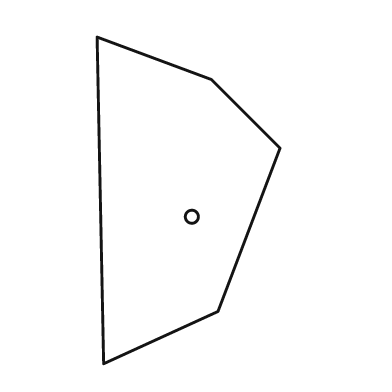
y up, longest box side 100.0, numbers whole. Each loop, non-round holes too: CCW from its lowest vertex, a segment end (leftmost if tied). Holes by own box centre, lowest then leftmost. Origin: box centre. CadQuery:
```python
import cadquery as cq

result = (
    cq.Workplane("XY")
    .moveTo(-26.0, -50.0)
    .lineTo(9.0, -34.0)
    .lineTo(28.0, 16.0)
    .lineTo(7.0, 37.0)
    .lineTo(-28.0, 50.0)
    .close()
    .moveTo(1.0, -5.0)
    .circle(2.0)
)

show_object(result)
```